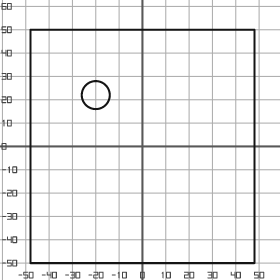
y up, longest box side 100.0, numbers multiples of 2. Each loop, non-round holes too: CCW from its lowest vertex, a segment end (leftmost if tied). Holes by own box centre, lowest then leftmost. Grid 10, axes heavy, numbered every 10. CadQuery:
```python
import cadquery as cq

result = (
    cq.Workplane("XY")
    .moveTo(-48.0, -50.0)
    .lineTo(48.0, -50.0)
    .lineTo(48.0, 50.0)
    .lineTo(-48.0, 50.0)
    .close()
    .moveTo(-20.0, 22.0)
    .circle(6.0)
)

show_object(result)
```